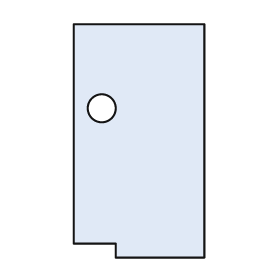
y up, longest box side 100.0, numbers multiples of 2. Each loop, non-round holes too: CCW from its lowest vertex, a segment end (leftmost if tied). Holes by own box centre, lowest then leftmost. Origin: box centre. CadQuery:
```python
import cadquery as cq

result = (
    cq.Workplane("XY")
    .moveTo(-10.0, -50.0)
    .lineTo(28.0, -50.0)
    .lineTo(28.0, 50.0)
    .lineTo(-28.0, 50.0)
    .lineTo(-28.0, -44.0)
    .lineTo(-10.0, -44.0)
    .close()
    .moveTo(-16.0, 14.0)
    .circle(6.0)
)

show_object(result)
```